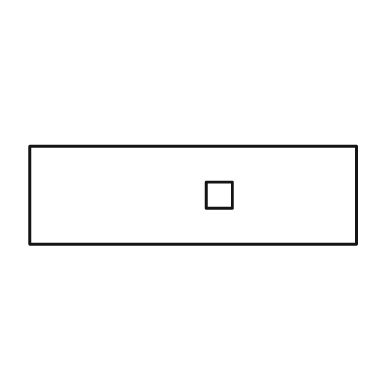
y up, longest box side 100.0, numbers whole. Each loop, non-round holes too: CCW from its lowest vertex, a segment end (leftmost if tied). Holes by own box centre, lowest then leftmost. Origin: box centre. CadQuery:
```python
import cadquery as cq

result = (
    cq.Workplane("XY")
    .moveTo(-50.0, -15.0)
    .lineTo(50.0, -15.0)
    .lineTo(50.0, 15.0)
    .lineTo(-50.0, 15.0)
    .close()
    .moveTo(4.0, -4.0)
    .lineTo(12.0, -4.0)
    .lineTo(12.0, 4.0)
    .lineTo(4.0, 4.0)
    .close()
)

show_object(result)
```